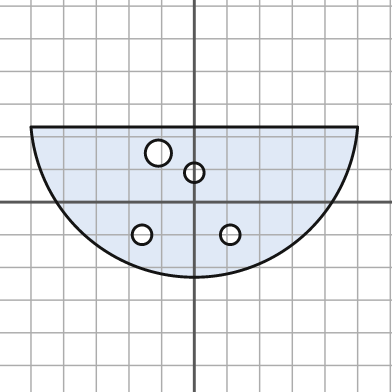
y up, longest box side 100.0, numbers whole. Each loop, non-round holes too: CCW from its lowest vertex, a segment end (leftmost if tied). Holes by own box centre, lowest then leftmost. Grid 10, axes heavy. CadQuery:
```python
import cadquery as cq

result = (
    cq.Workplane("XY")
    .moveTo(-50.0, 23.0)
    .threePointArc((0.0, -23.0), (50.0, 23.0))
    .close()
    .moveTo(-16.0, -10.0)
    .circle(3.0)
    .moveTo(11.0, -10.0)
    .circle(3.0)
    .moveTo(0.0, 9.0)
    .circle(3.0)
    .moveTo(-11.0, 15.0)
    .circle(4.0)
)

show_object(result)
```